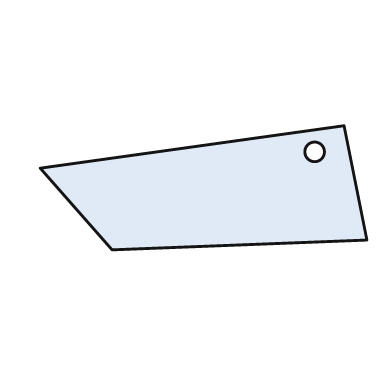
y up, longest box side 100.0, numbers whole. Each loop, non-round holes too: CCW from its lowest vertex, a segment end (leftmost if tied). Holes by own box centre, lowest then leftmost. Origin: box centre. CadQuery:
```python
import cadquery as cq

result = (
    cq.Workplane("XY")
    .moveTo(-28.0, -19.0)
    .lineTo(50.0, -16.0)
    .lineTo(43.0, 19.0)
    .lineTo(-50.0, 6.0)
    .close()
    .moveTo(34.0, 11.0)
    .circle(3.0)
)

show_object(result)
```